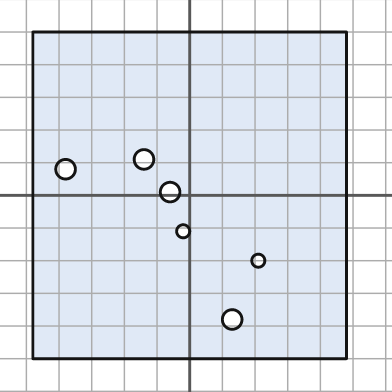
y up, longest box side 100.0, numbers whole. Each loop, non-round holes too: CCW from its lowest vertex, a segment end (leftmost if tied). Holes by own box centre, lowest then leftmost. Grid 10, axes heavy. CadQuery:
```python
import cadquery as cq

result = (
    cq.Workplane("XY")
    .moveTo(-48.0, -50.0)
    .lineTo(48.0, -50.0)
    .lineTo(48.0, 50.0)
    .lineTo(-48.0, 50.0)
    .close()
    .moveTo(13.0, -38.0)
    .circle(3.0)
    .moveTo(21.0, -20.0)
    .circle(2.0)
    .moveTo(-2.0, -11.0)
    .circle(2.0)
    .moveTo(-6.0, 1.0)
    .circle(3.0)
    .moveTo(-38.0, 8.0)
    .circle(3.0)
    .moveTo(-14.0, 11.0)
    .circle(3.0)
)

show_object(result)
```